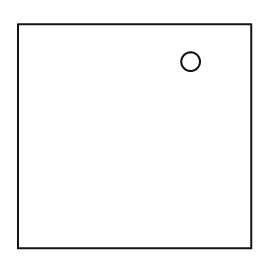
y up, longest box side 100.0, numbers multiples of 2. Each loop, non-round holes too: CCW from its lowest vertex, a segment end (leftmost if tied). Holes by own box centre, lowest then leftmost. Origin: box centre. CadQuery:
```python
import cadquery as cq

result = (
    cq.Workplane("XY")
    .moveTo(-50.0, -48.0)
    .lineTo(50.0, -48.0)
    .lineTo(50.0, 48.0)
    .lineTo(-50.0, 48.0)
    .close()
    .moveTo(24.0, 32.0)
    .circle(4.0)
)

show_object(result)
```